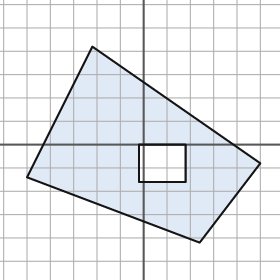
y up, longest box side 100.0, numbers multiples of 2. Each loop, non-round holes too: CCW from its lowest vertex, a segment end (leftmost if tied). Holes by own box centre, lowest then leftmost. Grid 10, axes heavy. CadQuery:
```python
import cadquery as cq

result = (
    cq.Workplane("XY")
    .moveTo(24.0, -42.0)
    .lineTo(50.0, -8.0)
    .lineTo(-22.0, 42.0)
    .lineTo(-50.0, -14.0)
    .close()
    .moveTo(-2.0, -16.0)
    .lineTo(18.0, -16.0)
    .lineTo(18.0, 0.0)
    .lineTo(-2.0, 0.0)
    .close()
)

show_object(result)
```